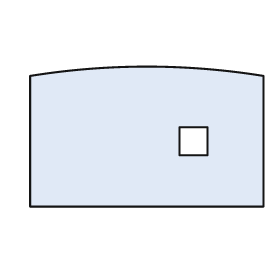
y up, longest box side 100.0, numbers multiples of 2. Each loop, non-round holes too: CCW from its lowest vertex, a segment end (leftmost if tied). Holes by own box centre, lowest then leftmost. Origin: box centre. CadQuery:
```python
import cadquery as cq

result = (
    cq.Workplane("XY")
    .moveTo(-50.0, -30.0)
    .lineTo(50.0, -30.0)
    .lineTo(50.0, 26.0)
    .threePointArc((0.0, 30.0), (-50.0, 26.0))
    .close()
    .moveTo(14.0, -8.0)
    .lineTo(26.0, -8.0)
    .lineTo(26.0, 4.0)
    .lineTo(14.0, 4.0)
    .close()
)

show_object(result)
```